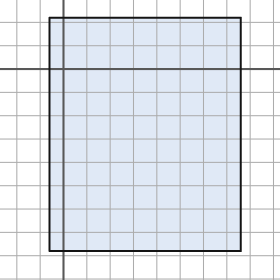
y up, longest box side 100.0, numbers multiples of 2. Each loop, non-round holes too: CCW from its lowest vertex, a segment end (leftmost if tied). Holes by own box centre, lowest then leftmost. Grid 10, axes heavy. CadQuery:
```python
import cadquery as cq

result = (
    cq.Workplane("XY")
    .moveTo(-6.0, -78.0)
    .lineTo(76.0, -78.0)
    .lineTo(76.0, 22.0)
    .lineTo(-6.0, 22.0)
    .close()
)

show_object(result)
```